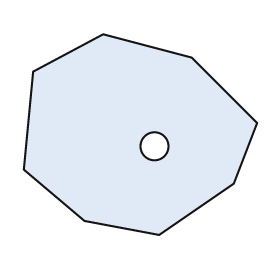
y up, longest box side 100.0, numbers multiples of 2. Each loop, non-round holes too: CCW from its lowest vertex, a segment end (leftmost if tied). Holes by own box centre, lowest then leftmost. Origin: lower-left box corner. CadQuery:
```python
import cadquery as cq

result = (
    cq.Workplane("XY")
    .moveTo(58.0, 0.0)
    .lineTo(90.0, 22.0)
    .lineTo(100.0, 48.0)
    .lineTo(72.0, 76.0)
    .lineTo(34.0, 86.0)
    .lineTo(4.0, 70.0)
    .lineTo(0.0, 28.0)
    .lineTo(26.0, 6.0)
    .close()
    .moveTo(56.0, 38.0)
    .circle(6.0)
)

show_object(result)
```